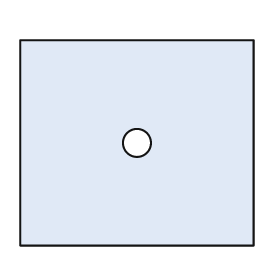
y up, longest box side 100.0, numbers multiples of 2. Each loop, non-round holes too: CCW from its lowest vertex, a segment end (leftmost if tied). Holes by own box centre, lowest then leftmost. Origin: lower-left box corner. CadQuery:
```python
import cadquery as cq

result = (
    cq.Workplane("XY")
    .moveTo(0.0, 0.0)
    .lineTo(100.0, 0.0)
    .lineTo(100.0, 88.0)
    .lineTo(0.0, 88.0)
    .close()
    .moveTo(50.0, 44.0)
    .circle(6.0)
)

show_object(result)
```